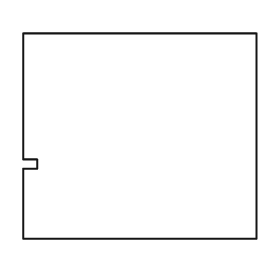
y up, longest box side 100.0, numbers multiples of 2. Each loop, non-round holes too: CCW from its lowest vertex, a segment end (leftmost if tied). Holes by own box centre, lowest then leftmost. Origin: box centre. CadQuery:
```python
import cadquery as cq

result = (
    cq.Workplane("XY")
    .moveTo(-50.0, -44.0)
    .lineTo(50.0, -44.0)
    .lineTo(50.0, 44.0)
    .lineTo(-50.0, 44.0)
    .lineTo(-50.0, -10.0)
    .lineTo(-44.0, -10.0)
    .lineTo(-44.0, -14.0)
    .lineTo(-50.0, -14.0)
    .close()
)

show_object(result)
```